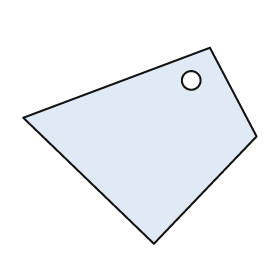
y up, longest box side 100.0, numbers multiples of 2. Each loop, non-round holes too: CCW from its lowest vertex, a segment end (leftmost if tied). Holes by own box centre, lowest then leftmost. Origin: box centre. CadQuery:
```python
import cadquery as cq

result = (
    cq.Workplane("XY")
    .moveTo(6.0, -42.0)
    .lineTo(50.0, 4.0)
    .lineTo(30.0, 42.0)
    .lineTo(-50.0, 12.0)
    .close()
    .moveTo(22.0, 28.0)
    .circle(4.0)
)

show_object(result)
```